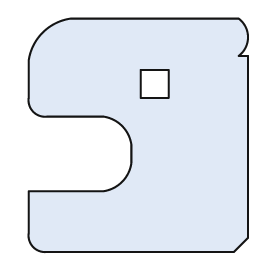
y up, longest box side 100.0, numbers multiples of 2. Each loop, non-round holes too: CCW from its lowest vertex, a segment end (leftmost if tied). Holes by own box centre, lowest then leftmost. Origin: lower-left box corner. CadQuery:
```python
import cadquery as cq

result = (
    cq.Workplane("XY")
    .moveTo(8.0, 0.0)
    .lineTo(88.0, 0.0)
    .lineTo(94.0, 6.0)
    .lineTo(94.0, 84.0)
    .lineTo(90.0, 84.0)
    .threePointArc((94.0, 92.0), (90.0, 100.0))
    .lineTo(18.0, 100.0)
    .threePointArc((6.0, 94.0), (0.0, 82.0))
    .lineTo(0.0, 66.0)
    .threePointArc((2.0, 60.0), (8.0, 58.0))
    .lineTo(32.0, 58.0)
    .threePointArc((40.0, 54.0), (44.0, 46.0))
    .lineTo(44.0, 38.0)
    .threePointArc((40.0, 30.0), (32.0, 26.0))
    .lineTo(0.0, 26.0)
    .lineTo(0.0, 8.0)
    .threePointArc((2.0, 2.0), (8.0, 0.0))
    .close()
    .moveTo(48.0, 66.0)
    .lineTo(60.0, 66.0)
    .lineTo(60.0, 78.0)
    .lineTo(48.0, 78.0)
    .close()
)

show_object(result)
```